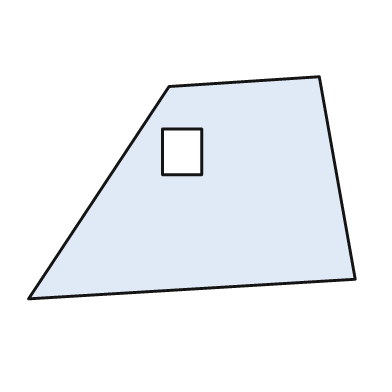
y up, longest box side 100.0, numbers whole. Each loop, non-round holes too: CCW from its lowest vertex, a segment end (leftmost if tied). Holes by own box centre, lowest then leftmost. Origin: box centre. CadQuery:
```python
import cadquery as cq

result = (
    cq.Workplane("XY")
    .moveTo(-50.0, -34.0)
    .lineTo(50.0, -28.0)
    .lineTo(39.0, 34.0)
    .lineTo(-7.0, 31.0)
    .close()
    .moveTo(-9.0, 4.0)
    .lineTo(3.0, 4.0)
    .lineTo(3.0, 18.0)
    .lineTo(-9.0, 18.0)
    .close()
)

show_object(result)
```